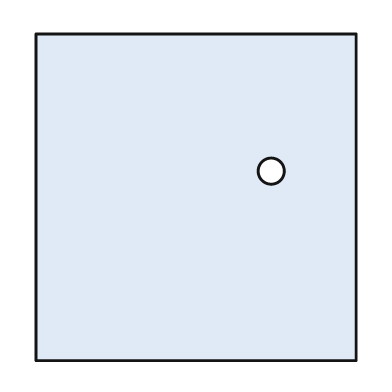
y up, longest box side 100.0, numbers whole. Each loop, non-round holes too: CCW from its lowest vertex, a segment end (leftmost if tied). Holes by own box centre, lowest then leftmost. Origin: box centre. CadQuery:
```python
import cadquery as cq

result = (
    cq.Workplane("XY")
    .moveTo(-49.0, -50.0)
    .lineTo(49.0, -50.0)
    .lineTo(49.0, 50.0)
    .lineTo(-49.0, 50.0)
    .close()
    .moveTo(23.0, 8.0)
    .circle(4.0)
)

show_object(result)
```